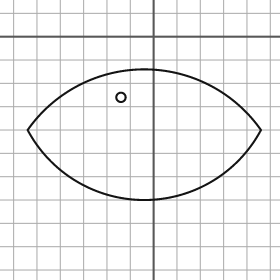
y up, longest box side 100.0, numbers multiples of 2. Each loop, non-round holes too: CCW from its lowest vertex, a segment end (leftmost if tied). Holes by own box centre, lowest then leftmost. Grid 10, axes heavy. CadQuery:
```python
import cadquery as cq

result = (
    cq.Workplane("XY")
    .moveTo(-54.0, -40.0)
    .threePointArc((-4.0, -70.0), (46.0, -40.0))
    .threePointArc((-4.0, -14.0), (-54.0, -40.0))
    .close()
    .moveTo(-14.0, -26.0)
    .circle(2.0)
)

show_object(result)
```